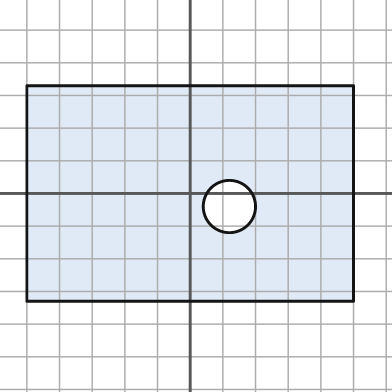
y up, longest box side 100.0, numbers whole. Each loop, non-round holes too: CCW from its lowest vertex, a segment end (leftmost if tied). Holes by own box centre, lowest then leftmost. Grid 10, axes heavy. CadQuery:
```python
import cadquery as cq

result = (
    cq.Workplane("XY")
    .moveTo(-50.0, -33.0)
    .lineTo(50.0, -33.0)
    .lineTo(50.0, 33.0)
    .lineTo(-50.0, 33.0)
    .close()
    .moveTo(12.0, -4.0)
    .circle(8.0)
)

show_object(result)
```